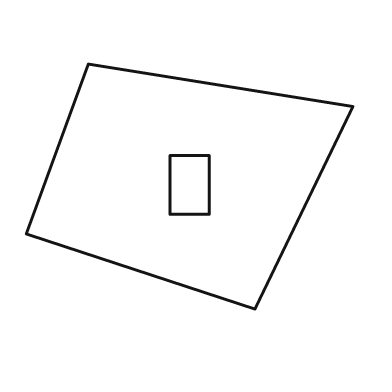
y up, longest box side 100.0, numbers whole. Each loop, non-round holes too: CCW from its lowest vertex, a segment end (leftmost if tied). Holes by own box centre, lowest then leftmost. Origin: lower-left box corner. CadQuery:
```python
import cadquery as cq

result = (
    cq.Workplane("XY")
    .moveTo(70.0, 0.0)
    .lineTo(100.0, 62.0)
    .lineTo(19.0, 75.0)
    .lineTo(0.0, 23.0)
    .close()
    .moveTo(44.0, 29.0)
    .lineTo(56.0, 29.0)
    .lineTo(56.0, 47.0)
    .lineTo(44.0, 47.0)
    .close()
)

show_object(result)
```